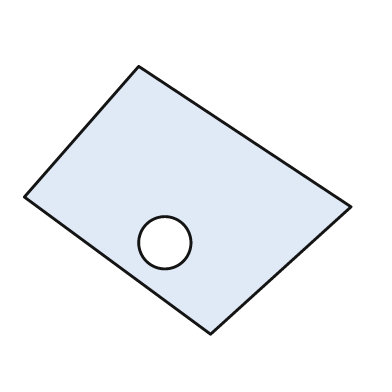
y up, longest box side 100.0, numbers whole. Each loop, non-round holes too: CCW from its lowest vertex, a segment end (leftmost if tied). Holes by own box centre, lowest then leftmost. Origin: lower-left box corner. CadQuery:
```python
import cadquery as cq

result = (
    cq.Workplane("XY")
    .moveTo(57.0, 0.0)
    .lineTo(100.0, 39.0)
    .lineTo(35.0, 82.0)
    .lineTo(0.0, 42.0)
    .close()
    .moveTo(43.0, 28.0)
    .circle(8.0)
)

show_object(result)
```